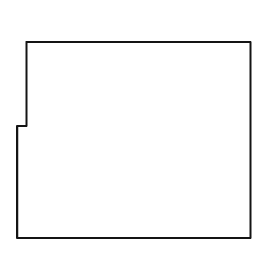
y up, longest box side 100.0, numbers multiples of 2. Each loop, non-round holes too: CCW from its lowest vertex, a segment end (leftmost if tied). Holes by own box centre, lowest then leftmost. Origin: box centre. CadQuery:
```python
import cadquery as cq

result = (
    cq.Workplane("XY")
    .moveTo(-50.0, -42.0)
    .lineTo(50.0, -42.0)
    .lineTo(50.0, 42.0)
    .lineTo(-46.0, 42.0)
    .lineTo(-46.0, 6.0)
    .lineTo(-50.0, 6.0)
    .close()
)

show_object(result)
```